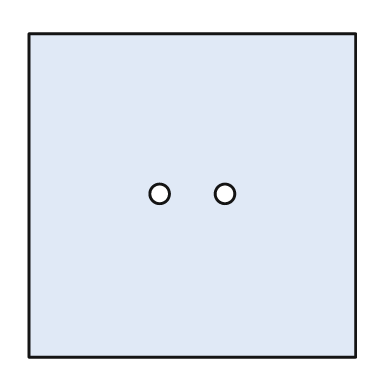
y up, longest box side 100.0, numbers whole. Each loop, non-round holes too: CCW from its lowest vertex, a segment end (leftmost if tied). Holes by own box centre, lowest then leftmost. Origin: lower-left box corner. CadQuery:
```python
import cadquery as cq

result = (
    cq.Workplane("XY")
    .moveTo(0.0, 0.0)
    .lineTo(100.0, 0.0)
    .lineTo(100.0, 99.0)
    .lineTo(0.0, 99.0)
    .close()
    .moveTo(40.0, 50.0)
    .circle(3.0)
    .moveTo(60.0, 50.0)
    .circle(3.0)
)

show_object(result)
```